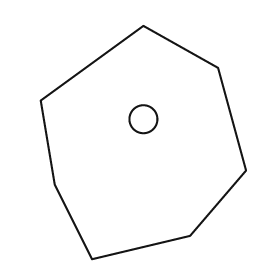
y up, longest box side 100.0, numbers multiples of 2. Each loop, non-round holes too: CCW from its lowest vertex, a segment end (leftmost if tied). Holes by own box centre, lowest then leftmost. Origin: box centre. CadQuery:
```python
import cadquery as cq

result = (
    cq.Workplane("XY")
    .moveTo(-22.0, -50.0)
    .lineTo(20.0, -40.0)
    .lineTo(44.0, -12.0)
    .lineTo(32.0, 32.0)
    .lineTo(0.0, 50.0)
    .lineTo(-44.0, 18.0)
    .lineTo(-38.0, -18.0)
    .close()
    .moveTo(0.0, 10.0)
    .circle(6.0)
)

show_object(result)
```